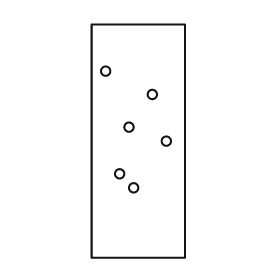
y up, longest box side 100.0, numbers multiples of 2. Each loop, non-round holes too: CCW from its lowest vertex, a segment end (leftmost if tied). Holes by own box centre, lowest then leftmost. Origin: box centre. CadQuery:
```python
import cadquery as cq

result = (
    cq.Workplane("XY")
    .moveTo(-20.0, -50.0)
    .lineTo(20.0, -50.0)
    .lineTo(20.0, 50.0)
    .lineTo(-20.0, 50.0)
    .close()
    .moveTo(-2.0, -20.0)
    .circle(2.0)
    .moveTo(-8.0, -14.0)
    .circle(2.0)
    .moveTo(12.0, 0.0)
    .circle(2.0)
    .moveTo(-4.0, 6.0)
    .circle(2.0)
    .moveTo(6.0, 20.0)
    .circle(2.0)
    .moveTo(-14.0, 30.0)
    .circle(2.0)
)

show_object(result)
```